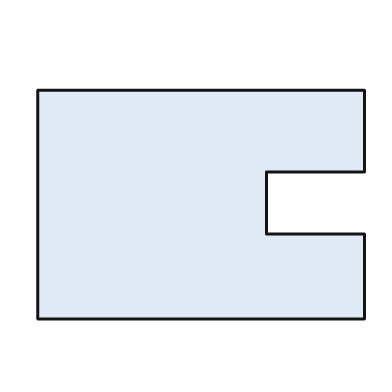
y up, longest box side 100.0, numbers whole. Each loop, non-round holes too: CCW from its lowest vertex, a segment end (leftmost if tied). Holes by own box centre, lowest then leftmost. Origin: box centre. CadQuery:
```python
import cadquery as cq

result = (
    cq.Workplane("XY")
    .moveTo(-50.0, -35.0)
    .lineTo(50.0, -35.0)
    .lineTo(50.0, -9.0)
    .lineTo(20.0, -9.0)
    .lineTo(20.0, 10.0)
    .lineTo(50.0, 10.0)
    .lineTo(50.0, 35.0)
    .lineTo(-50.0, 35.0)
    .close()
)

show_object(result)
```